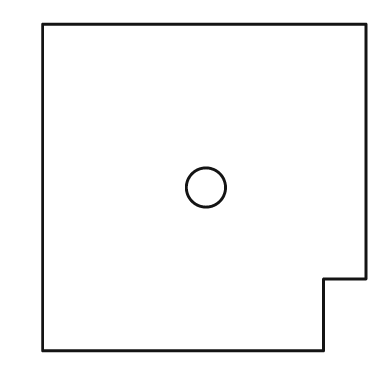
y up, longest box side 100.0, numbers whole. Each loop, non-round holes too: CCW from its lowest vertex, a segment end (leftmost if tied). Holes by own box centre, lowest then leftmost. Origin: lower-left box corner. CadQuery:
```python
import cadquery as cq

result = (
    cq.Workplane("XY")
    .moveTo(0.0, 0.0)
    .lineTo(86.0, 0.0)
    .lineTo(86.0, 22.0)
    .lineTo(99.0, 22.0)
    .lineTo(99.0, 100.0)
    .lineTo(0.0, 100.0)
    .close()
    .moveTo(50.0, 50.0)
    .circle(6.0)
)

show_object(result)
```